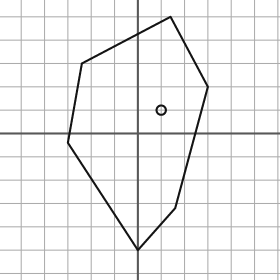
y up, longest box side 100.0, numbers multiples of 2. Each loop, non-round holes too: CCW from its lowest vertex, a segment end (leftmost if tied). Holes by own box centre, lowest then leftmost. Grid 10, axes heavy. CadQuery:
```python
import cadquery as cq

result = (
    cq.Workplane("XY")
    .moveTo(0.0, -50.0)
    .lineTo(16.0, -32.0)
    .lineTo(30.0, 20.0)
    .lineTo(14.0, 50.0)
    .lineTo(-24.0, 30.0)
    .lineTo(-30.0, -4.0)
    .close()
    .moveTo(10.0, 10.0)
    .circle(2.0)
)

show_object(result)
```